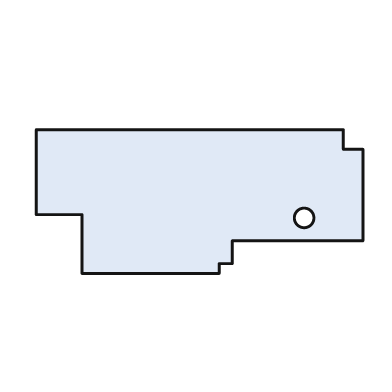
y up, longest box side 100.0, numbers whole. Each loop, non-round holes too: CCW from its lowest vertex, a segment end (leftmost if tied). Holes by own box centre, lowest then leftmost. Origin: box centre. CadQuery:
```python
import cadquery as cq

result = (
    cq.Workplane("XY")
    .moveTo(-36.0, -22.0)
    .lineTo(6.0, -22.0)
    .lineTo(6.0, -19.0)
    .lineTo(10.0, -19.0)
    .lineTo(10.0, -12.0)
    .lineTo(50.0, -12.0)
    .lineTo(50.0, 16.0)
    .lineTo(44.0, 16.0)
    .lineTo(44.0, 22.0)
    .lineTo(-50.0, 22.0)
    .lineTo(-50.0, -4.0)
    .lineTo(-36.0, -4.0)
    .close()
    .moveTo(32.0, -5.0)
    .circle(3.0)
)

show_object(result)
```